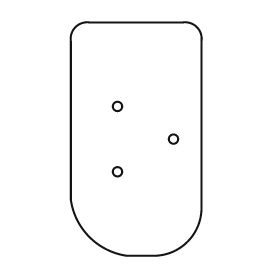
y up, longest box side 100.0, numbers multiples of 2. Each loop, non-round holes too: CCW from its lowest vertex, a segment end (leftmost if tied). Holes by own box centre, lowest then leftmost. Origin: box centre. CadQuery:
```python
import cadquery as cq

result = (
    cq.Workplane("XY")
    .moveTo(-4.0, -50.0)
    .lineTo(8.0, -50.0)
    .threePointArc((22.0, -44.0), (28.0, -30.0))
    .lineTo(28.0, 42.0)
    .threePointArc((26.0, 48.0), (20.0, 50.0))
    .lineTo(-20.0, 50.0)
    .threePointArc((-26.0, 48.0), (-28.0, 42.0))
    .lineTo(-28.0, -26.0)
    .threePointArc((-20.0, -42.0), (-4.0, -50.0))
    .close()
    .moveTo(-8.0, -14.0)
    .circle(2.0)
    .moveTo(16.0, 0.0)
    .circle(2.0)
    .moveTo(-8.0, 14.0)
    .circle(2.0)
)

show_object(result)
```